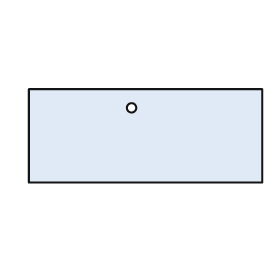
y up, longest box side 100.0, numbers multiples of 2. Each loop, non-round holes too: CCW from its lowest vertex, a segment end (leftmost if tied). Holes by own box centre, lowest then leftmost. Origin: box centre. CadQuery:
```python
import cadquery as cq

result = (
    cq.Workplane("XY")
    .moveTo(-50.0, -20.0)
    .lineTo(50.0, -20.0)
    .lineTo(50.0, 20.0)
    .lineTo(-50.0, 20.0)
    .close()
    .moveTo(-6.0, 12.0)
    .circle(2.0)
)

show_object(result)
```